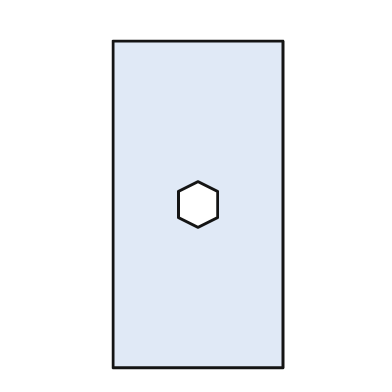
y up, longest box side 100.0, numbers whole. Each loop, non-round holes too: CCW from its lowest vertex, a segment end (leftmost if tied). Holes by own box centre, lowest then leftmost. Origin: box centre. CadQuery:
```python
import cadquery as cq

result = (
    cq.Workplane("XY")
    .moveTo(-26.0, -50.0)
    .lineTo(26.0, -50.0)
    .lineTo(26.0, 50.0)
    .lineTo(-26.0, 50.0)
    .close()
    .moveTo(0.0, -7.0)
    .lineTo(6.0, -4.0)
    .lineTo(6.0, 4.0)
    .lineTo(0.0, 7.0)
    .lineTo(-6.0, 4.0)
    .lineTo(-6.0, -4.0)
    .close()
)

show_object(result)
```